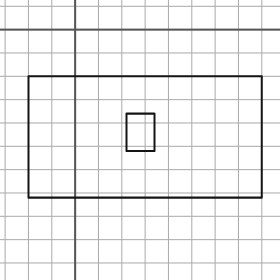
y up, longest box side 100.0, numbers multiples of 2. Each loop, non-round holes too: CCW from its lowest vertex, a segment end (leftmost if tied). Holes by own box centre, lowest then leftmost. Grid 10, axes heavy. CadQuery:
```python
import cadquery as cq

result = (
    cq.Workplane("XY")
    .moveTo(-20.0, -72.0)
    .lineTo(80.0, -72.0)
    .lineTo(80.0, -20.0)
    .lineTo(-20.0, -20.0)
    .close()
    .moveTo(22.0, -52.0)
    .lineTo(34.0, -52.0)
    .lineTo(34.0, -36.0)
    .lineTo(22.0, -36.0)
    .close()
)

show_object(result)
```